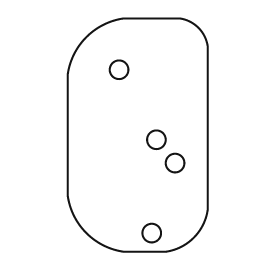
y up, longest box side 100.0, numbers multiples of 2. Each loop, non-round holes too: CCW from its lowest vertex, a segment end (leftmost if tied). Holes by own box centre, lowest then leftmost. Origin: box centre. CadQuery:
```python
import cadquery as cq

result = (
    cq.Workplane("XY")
    .moveTo(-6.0, -50.0)
    .lineTo(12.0, -50.0)
    .threePointArc((24.0, -44.0), (30.0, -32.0))
    .lineTo(30.0, 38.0)
    .threePointArc((26.0, 46.0), (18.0, 50.0))
    .lineTo(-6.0, 50.0)
    .threePointArc((-22.0, 42.0), (-30.0, 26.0))
    .lineTo(-30.0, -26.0)
    .threePointArc((-22.0, -42.0), (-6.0, -50.0))
    .close()
    .moveTo(6.0, -42.0)
    .circle(4.0)
    .moveTo(16.0, -12.0)
    .circle(4.0)
    .moveTo(8.0, -2.0)
    .circle(4.0)
    .moveTo(-8.0, 28.0)
    .circle(4.0)
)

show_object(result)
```